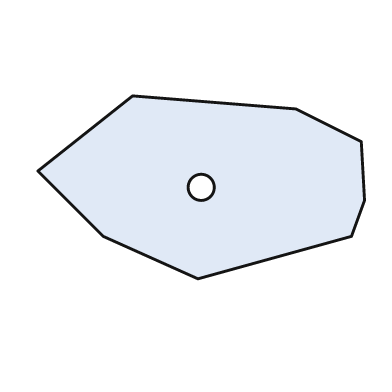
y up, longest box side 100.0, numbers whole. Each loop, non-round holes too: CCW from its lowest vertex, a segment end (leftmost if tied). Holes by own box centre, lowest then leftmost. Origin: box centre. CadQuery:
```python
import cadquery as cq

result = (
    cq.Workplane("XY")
    .moveTo(-1.0, -28.0)
    .lineTo(46.0, -15.0)
    .lineTo(50.0, -4.0)
    .lineTo(49.0, 14.0)
    .lineTo(29.0, 24.0)
    .lineTo(-21.0, 28.0)
    .lineTo(-50.0, 5.0)
    .lineTo(-30.0, -15.0)
    .close()
    .moveTo(0.0, 0.0)
    .circle(4.0)
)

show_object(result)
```